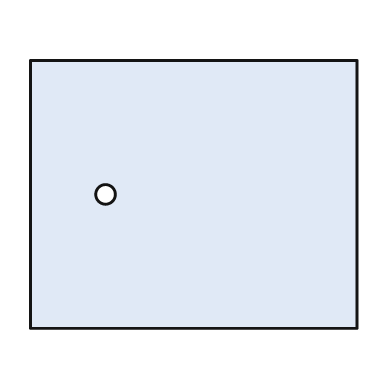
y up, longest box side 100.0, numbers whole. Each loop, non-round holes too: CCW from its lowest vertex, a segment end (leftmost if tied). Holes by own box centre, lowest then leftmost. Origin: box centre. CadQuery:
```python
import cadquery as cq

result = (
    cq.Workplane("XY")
    .moveTo(-50.0, -41.0)
    .lineTo(50.0, -41.0)
    .lineTo(50.0, 41.0)
    .lineTo(-50.0, 41.0)
    .close()
    .moveTo(-27.0, 0.0)
    .circle(3.0)
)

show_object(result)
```